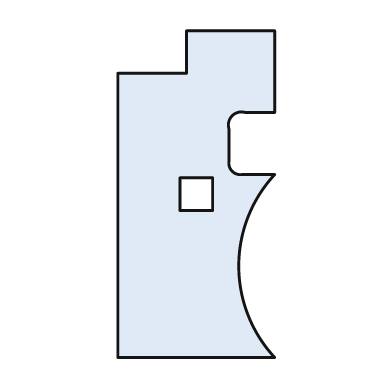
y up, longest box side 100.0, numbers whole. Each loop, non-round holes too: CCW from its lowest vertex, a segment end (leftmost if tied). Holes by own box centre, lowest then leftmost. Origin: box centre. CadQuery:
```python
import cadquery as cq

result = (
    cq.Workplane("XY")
    .moveTo(-24.0, -50.0)
    .lineTo(24.0, -50.0)
    .threePointArc((13.0, -22.0), (24.0, 6.0))
    .lineTo(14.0, 6.0)
    .threePointArc((11.0, 7.0), (10.0, 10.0))
    .lineTo(10.0, 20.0)
    .threePointArc((11.0, 24.0), (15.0, 25.0))
    .lineTo(24.0, 25.0)
    .lineTo(24.0, 50.0)
    .lineTo(-3.0, 50.0)
    .lineTo(-3.0, 37.0)
    .lineTo(-24.0, 37.0)
    .close()
    .moveTo(-5.0, -5.0)
    .lineTo(5.0, -5.0)
    .lineTo(5.0, 5.0)
    .lineTo(-5.0, 5.0)
    .close()
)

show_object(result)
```